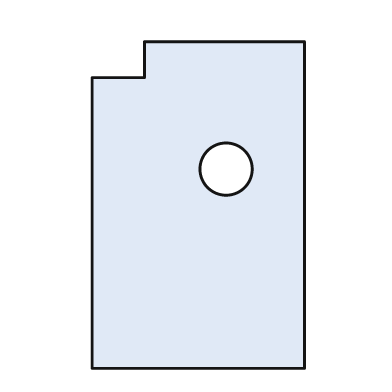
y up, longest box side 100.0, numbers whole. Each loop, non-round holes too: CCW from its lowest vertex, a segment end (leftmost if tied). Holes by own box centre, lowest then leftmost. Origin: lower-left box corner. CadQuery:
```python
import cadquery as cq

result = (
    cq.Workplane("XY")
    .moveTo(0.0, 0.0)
    .lineTo(65.0, 0.0)
    .lineTo(65.0, 100.0)
    .lineTo(16.0, 100.0)
    .lineTo(16.0, 89.0)
    .lineTo(0.0, 89.0)
    .close()
    .moveTo(41.0, 61.0)
    .circle(8.0)
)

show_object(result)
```